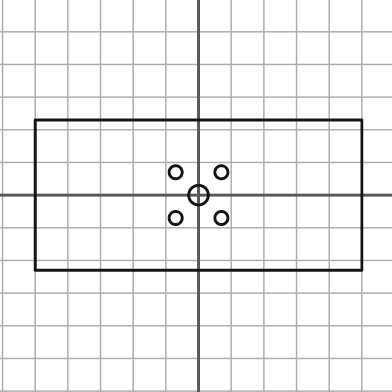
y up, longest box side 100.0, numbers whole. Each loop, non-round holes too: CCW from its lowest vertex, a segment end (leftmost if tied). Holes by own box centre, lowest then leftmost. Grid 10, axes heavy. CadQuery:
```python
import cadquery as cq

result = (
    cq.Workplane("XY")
    .moveTo(-50.0, -23.0)
    .lineTo(50.0, -23.0)
    .lineTo(50.0, 23.0)
    .lineTo(-50.0, 23.0)
    .close()
    .moveTo(-7.0, -7.0)
    .circle(2.0)
    .moveTo(7.0, -7.0)
    .circle(2.0)
    .moveTo(0.0, 0.0)
    .circle(3.0)
    .moveTo(-7.0, 7.0)
    .circle(2.0)
    .moveTo(7.0, 7.0)
    .circle(2.0)
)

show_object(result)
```